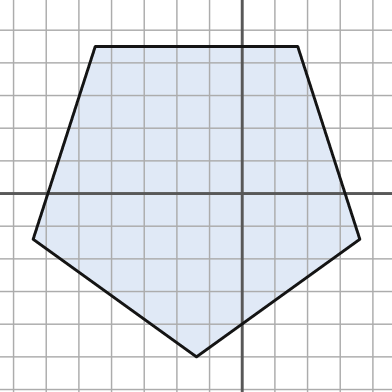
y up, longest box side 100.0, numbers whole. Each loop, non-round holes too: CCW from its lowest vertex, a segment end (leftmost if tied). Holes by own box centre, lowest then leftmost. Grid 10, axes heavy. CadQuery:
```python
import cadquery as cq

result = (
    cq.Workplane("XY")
    .moveTo(-14.0, -50.0)
    .lineTo(36.0, -14.0)
    .lineTo(17.0, 45.0)
    .lineTo(-45.0, 45.0)
    .lineTo(-64.0, -14.0)
    .close()
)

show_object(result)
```